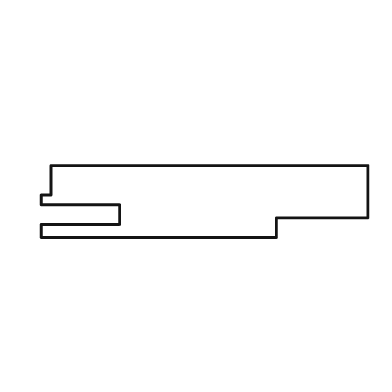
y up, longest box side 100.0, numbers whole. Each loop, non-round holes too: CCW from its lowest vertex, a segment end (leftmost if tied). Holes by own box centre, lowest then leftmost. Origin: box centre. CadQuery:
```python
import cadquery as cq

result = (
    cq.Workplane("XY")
    .moveTo(-50.0, -11.0)
    .lineTo(22.0, -11.0)
    .lineTo(22.0, -5.0)
    .lineTo(50.0, -5.0)
    .lineTo(50.0, 11.0)
    .lineTo(-47.0, 11.0)
    .lineTo(-47.0, 2.0)
    .lineTo(-50.0, 2.0)
    .lineTo(-50.0, -1.0)
    .lineTo(-26.0, -1.0)
    .lineTo(-26.0, -7.0)
    .lineTo(-50.0, -7.0)
    .close()
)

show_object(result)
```